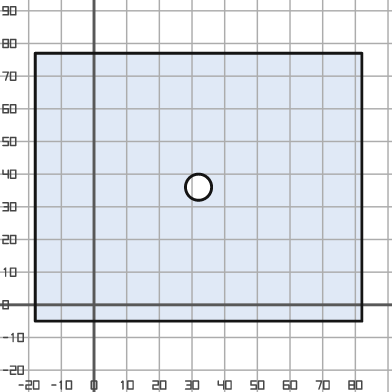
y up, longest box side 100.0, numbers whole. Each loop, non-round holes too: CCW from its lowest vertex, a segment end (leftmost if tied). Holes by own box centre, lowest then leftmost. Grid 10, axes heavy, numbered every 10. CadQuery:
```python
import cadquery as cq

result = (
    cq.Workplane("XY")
    .moveTo(-18.0, -5.0)
    .lineTo(82.0, -5.0)
    .lineTo(82.0, 77.0)
    .lineTo(-18.0, 77.0)
    .close()
    .moveTo(32.0, 36.0)
    .circle(4.0)
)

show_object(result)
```